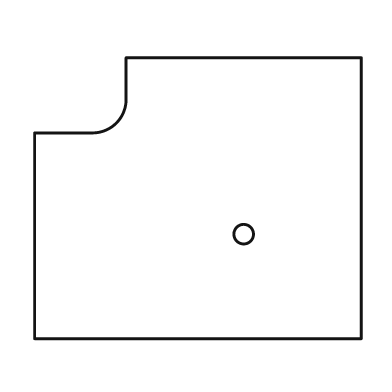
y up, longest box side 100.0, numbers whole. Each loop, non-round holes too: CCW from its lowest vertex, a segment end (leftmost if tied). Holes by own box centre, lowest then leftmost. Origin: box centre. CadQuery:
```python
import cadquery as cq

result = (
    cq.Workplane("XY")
    .moveTo(-50.0, -43.0)
    .lineTo(50.0, -43.0)
    .lineTo(50.0, 43.0)
    .lineTo(-22.0, 43.0)
    .lineTo(-22.0, 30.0)
    .threePointArc((-25.0, 23.0), (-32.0, 20.0))
    .lineTo(-50.0, 20.0)
    .close()
    .moveTo(14.0, -11.0)
    .circle(3.0)
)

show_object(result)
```